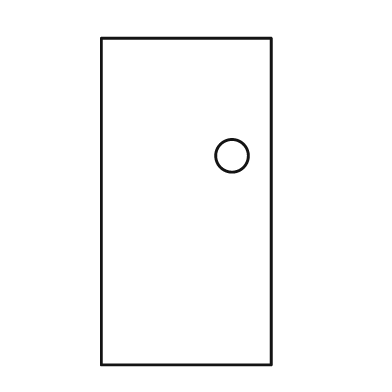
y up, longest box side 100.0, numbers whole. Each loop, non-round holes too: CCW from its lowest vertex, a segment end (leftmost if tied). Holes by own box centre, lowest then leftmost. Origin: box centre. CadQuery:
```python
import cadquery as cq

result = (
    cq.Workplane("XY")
    .moveTo(-26.0, -50.0)
    .lineTo(26.0, -50.0)
    .lineTo(26.0, 50.0)
    .lineTo(-26.0, 50.0)
    .close()
    .moveTo(14.0, 14.0)
    .circle(5.0)
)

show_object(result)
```